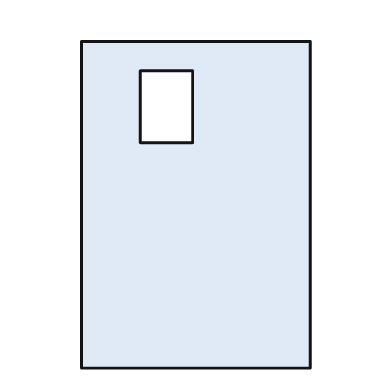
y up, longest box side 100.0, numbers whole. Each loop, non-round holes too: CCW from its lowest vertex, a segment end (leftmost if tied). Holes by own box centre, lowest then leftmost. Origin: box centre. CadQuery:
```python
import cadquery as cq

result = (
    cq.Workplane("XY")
    .moveTo(-35.0, -50.0)
    .lineTo(35.0, -50.0)
    .lineTo(35.0, 50.0)
    .lineTo(-35.0, 50.0)
    .close()
    .moveTo(-17.0, 19.0)
    .lineTo(-1.0, 19.0)
    .lineTo(-1.0, 41.0)
    .lineTo(-17.0, 41.0)
    .close()
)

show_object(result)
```